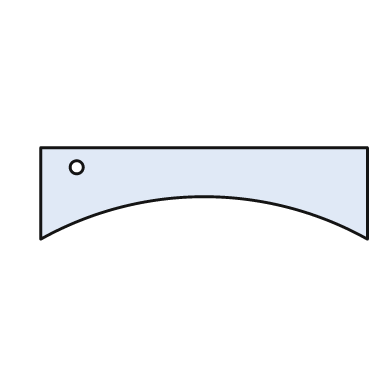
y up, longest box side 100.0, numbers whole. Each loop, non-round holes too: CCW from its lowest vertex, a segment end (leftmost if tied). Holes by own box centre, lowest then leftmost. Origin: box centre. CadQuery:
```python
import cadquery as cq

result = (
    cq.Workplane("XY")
    .moveTo(-50.0, -14.0)
    .threePointArc((0.0, -1.0), (50.0, -14.0))
    .lineTo(50.0, 14.0)
    .lineTo(-50.0, 14.0)
    .close()
    .moveTo(-39.0, 8.0)
    .circle(2.0)
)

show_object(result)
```